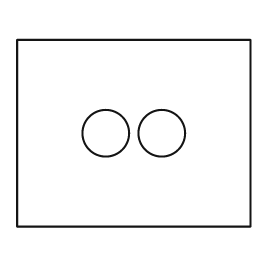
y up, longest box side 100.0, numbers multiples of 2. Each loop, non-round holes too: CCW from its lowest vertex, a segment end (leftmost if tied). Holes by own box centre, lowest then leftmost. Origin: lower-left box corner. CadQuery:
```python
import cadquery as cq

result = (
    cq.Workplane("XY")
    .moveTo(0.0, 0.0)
    .lineTo(100.0, 0.0)
    .lineTo(100.0, 80.0)
    .lineTo(0.0, 80.0)
    .close()
    .moveTo(38.0, 40.0)
    .circle(10.0)
    .moveTo(62.0, 40.0)
    .circle(10.0)
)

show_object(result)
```